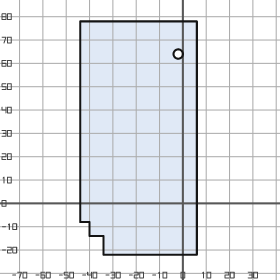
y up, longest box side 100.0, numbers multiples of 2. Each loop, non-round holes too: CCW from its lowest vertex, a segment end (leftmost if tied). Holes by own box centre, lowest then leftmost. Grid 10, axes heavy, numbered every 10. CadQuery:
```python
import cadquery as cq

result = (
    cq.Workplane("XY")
    .moveTo(-34.0, -22.0)
    .lineTo(6.0, -22.0)
    .lineTo(6.0, 78.0)
    .lineTo(-44.0, 78.0)
    .lineTo(-44.0, -8.0)
    .lineTo(-40.0, -8.0)
    .lineTo(-40.0, -14.0)
    .lineTo(-34.0, -14.0)
    .close()
    .moveTo(-2.0, 64.0)
    .circle(2.0)
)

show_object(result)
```